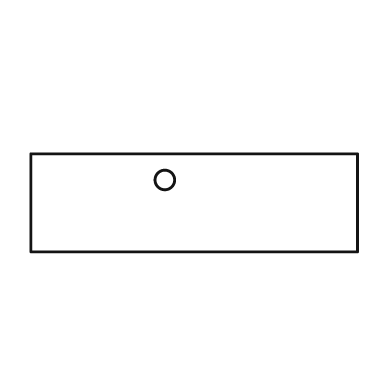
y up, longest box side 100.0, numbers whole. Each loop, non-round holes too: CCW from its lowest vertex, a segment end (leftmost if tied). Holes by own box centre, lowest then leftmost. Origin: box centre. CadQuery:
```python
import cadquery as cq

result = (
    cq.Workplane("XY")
    .moveTo(-50.0, -15.0)
    .lineTo(50.0, -15.0)
    .lineTo(50.0, 15.0)
    .lineTo(-50.0, 15.0)
    .close()
    .moveTo(-9.0, 7.0)
    .circle(3.0)
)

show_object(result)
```